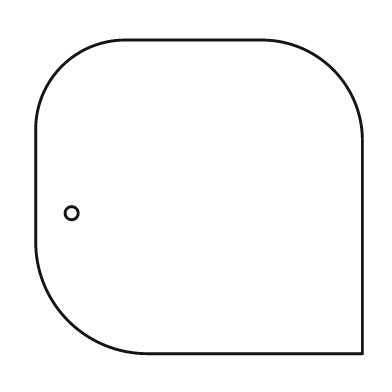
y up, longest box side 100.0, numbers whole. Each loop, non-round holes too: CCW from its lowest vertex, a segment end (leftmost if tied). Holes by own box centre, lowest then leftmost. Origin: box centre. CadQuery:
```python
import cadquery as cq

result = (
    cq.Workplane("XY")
    .moveTo(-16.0, -48.0)
    .lineTo(50.0, -48.0)
    .lineTo(50.0, 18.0)
    .threePointArc((41.0, 39.0), (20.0, 48.0))
    .lineTo(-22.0, 48.0)
    .threePointArc((-42.0, 40.0), (-50.0, 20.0))
    .lineTo(-50.0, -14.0)
    .threePointArc((-40.0, -38.0), (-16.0, -48.0))
    .close()
    .moveTo(-39.0, -5.0)
    .circle(2.0)
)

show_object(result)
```